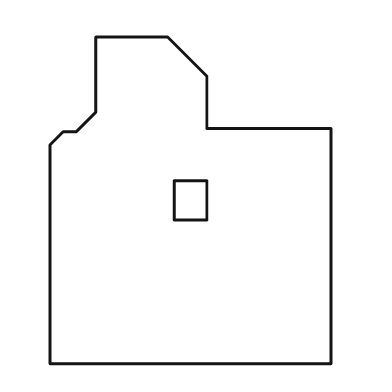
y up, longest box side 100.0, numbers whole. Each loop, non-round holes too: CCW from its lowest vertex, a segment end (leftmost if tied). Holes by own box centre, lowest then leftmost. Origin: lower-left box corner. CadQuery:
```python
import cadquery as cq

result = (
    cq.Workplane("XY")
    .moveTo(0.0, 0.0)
    .lineTo(86.0, 0.0)
    .lineTo(86.0, 72.0)
    .lineTo(48.0, 72.0)
    .lineTo(48.0, 88.0)
    .lineTo(36.0, 100.0)
    .lineTo(14.0, 100.0)
    .lineTo(14.0, 77.0)
    .lineTo(8.0, 71.0)
    .lineTo(4.0, 71.0)
    .lineTo(0.0, 67.0)
    .close()
    .moveTo(38.0, 44.0)
    .lineTo(48.0, 44.0)
    .lineTo(48.0, 56.0)
    .lineTo(38.0, 56.0)
    .close()
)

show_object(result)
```